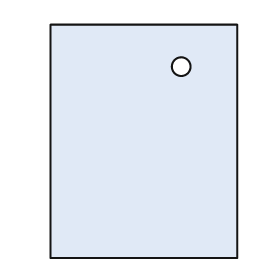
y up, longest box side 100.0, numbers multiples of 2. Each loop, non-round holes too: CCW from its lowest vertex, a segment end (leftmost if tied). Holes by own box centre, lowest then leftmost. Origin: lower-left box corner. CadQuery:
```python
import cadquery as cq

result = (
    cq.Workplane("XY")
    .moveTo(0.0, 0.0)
    .lineTo(80.0, 0.0)
    .lineTo(80.0, 100.0)
    .lineTo(0.0, 100.0)
    .close()
    .moveTo(56.0, 82.0)
    .circle(4.0)
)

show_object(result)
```